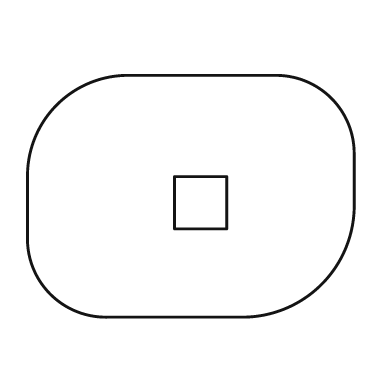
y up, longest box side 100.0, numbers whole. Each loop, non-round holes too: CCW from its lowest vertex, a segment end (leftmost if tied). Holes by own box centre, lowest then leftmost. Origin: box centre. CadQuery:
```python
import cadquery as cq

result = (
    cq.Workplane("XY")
    .moveTo(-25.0, -37.0)
    .lineTo(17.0, -37.0)
    .threePointArc((40.0, -27.0), (50.0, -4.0))
    .lineTo(50.0, 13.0)
    .threePointArc((43.0, 30.0), (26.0, 37.0))
    .lineTo(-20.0, 37.0)
    .threePointArc((-41.0, 28.0), (-50.0, 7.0))
    .lineTo(-50.0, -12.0)
    .threePointArc((-43.0, -30.0), (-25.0, -37.0))
    .close()
    .moveTo(-5.0, -10.0)
    .lineTo(11.0, -10.0)
    .lineTo(11.0, 6.0)
    .lineTo(-5.0, 6.0)
    .close()
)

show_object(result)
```